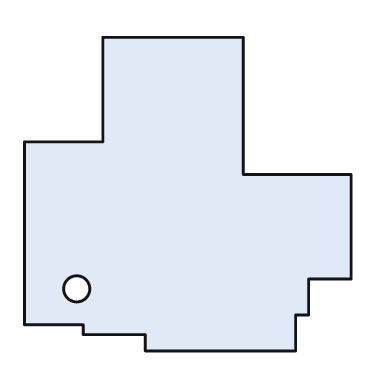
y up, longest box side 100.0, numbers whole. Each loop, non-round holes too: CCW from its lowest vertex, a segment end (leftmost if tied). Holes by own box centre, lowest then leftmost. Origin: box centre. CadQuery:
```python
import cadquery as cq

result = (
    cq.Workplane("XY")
    .moveTo(-13.0, -48.0)
    .lineTo(33.0, -48.0)
    .lineTo(33.0, -37.0)
    .lineTo(37.0, -37.0)
    .lineTo(37.0, -26.0)
    .lineTo(50.0, -26.0)
    .lineTo(50.0, 6.0)
    .lineTo(17.0, 6.0)
    .lineTo(17.0, 48.0)
    .lineTo(-26.0, 48.0)
    .lineTo(-26.0, 16.0)
    .lineTo(-50.0, 16.0)
    .lineTo(-50.0, -40.0)
    .lineTo(-32.0, -40.0)
    .lineTo(-32.0, -43.0)
    .lineTo(-13.0, -43.0)
    .close()
    .moveTo(-34.0, -29.0)
    .circle(4.0)
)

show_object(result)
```